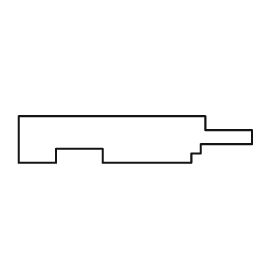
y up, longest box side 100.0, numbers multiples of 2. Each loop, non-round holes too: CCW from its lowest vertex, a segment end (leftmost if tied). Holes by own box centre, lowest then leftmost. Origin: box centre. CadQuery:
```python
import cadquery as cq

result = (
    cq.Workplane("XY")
    .moveTo(-50.0, -10.0)
    .lineTo(-34.0, -10.0)
    .lineTo(-34.0, -4.0)
    .lineTo(-14.0, -4.0)
    .lineTo(-14.0, -10.0)
    .lineTo(24.0, -10.0)
    .lineTo(24.0, -6.0)
    .lineTo(28.0, -6.0)
    .lineTo(28.0, -2.0)
    .lineTo(50.0, -2.0)
    .lineTo(50.0, 4.0)
    .lineTo(30.0, 4.0)
    .lineTo(30.0, 10.0)
    .lineTo(-50.0, 10.0)
    .close()
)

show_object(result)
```